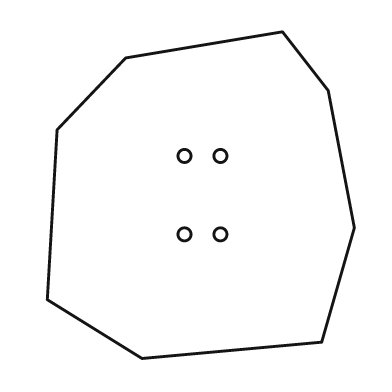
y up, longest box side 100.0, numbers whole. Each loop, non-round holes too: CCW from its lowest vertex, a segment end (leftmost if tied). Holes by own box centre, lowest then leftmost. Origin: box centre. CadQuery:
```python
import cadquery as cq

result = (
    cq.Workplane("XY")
    .moveTo(-18.0, -50.0)
    .lineTo(37.0, -45.0)
    .lineTo(47.0, -10.0)
    .lineTo(39.0, 32.0)
    .lineTo(25.0, 50.0)
    .lineTo(-23.0, 42.0)
    .lineTo(-44.0, 20.0)
    .lineTo(-47.0, -32.0)
    .close()
    .moveTo(-5.0, -12.0)
    .circle(2.0)
    .moveTo(6.0, -12.0)
    .circle(2.0)
    .moveTo(-5.0, 12.0)
    .circle(2.0)
    .moveTo(6.0, 12.0)
    .circle(2.0)
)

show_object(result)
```